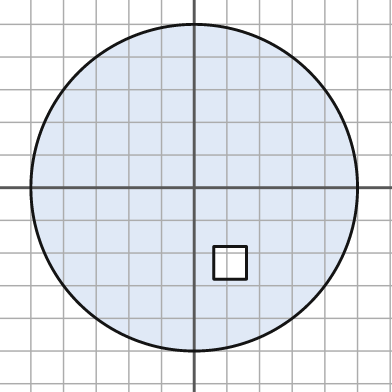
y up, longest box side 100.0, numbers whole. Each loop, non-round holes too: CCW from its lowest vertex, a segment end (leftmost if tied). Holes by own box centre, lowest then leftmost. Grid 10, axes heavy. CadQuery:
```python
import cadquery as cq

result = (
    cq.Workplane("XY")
    .moveTo(0.0, 0.0)
    .circle(50.0)
    .moveTo(6.0, -28.0)
    .lineTo(16.0, -28.0)
    .lineTo(16.0, -18.0)
    .lineTo(6.0, -18.0)
    .close()
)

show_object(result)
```